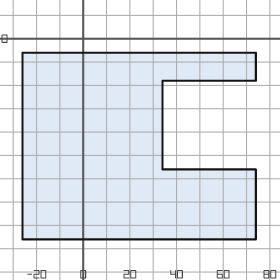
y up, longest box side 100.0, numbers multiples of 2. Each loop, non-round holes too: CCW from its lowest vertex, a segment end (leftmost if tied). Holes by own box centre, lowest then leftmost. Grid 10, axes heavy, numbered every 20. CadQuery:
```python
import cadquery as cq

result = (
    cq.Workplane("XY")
    .moveTo(-26.0, -86.0)
    .lineTo(74.0, -86.0)
    .lineTo(74.0, -56.0)
    .lineTo(34.0, -56.0)
    .lineTo(34.0, -18.0)
    .lineTo(74.0, -18.0)
    .lineTo(74.0, -6.0)
    .lineTo(-26.0, -6.0)
    .close()
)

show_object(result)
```